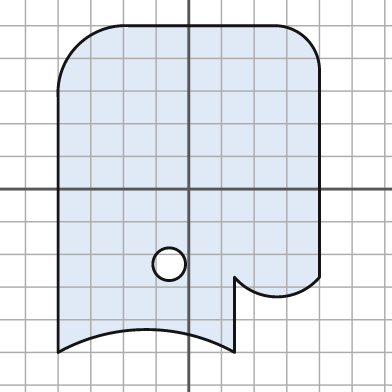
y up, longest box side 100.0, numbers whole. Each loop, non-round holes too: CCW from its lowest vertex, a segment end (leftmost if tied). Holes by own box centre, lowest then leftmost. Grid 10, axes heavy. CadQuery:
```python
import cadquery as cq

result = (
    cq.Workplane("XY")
    .moveTo(-40.0, -50.0)
    .threePointArc((-13.0, -43.0), (14.0, -50.0))
    .lineTo(14.0, -27.0)
    .threePointArc((27.0, -33.0), (40.0, -27.0))
    .lineTo(40.0, 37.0)
    .threePointArc((36.0, 46.0), (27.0, 50.0))
    .lineTo(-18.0, 50.0)
    .threePointArc((-34.0, 44.0), (-40.0, 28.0))
    .close()
    .moveTo(-6.0, -23.0)
    .circle(5.0)
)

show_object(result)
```